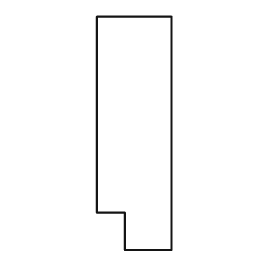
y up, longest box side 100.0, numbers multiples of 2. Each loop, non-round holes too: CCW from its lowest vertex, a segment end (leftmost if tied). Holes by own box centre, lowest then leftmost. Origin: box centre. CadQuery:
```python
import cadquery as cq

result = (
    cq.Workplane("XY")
    .moveTo(-4.0, -50.0)
    .lineTo(16.0, -50.0)
    .lineTo(16.0, 50.0)
    .lineTo(-16.0, 50.0)
    .lineTo(-16.0, -34.0)
    .lineTo(-4.0, -34.0)
    .close()
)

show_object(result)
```